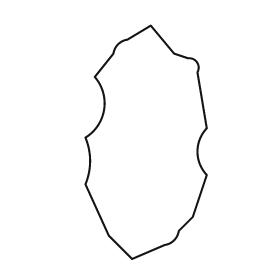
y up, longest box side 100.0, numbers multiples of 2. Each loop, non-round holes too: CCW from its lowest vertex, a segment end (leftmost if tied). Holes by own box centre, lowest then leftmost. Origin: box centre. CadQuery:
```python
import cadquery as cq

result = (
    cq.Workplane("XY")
    .moveTo(-6.0, -50.0)
    .lineTo(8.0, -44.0)
    .threePointArc((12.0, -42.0), (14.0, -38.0))
    .lineTo(20.0, -32.0)
    .lineTo(26.0, -14.0)
    .threePointArc((22.0, -4.0), (26.0, 6.0))
    .lineTo(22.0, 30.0)
    .threePointArc((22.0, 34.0), (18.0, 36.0))
    .lineTo(12.0, 38.0)
    .lineTo(2.0, 50.0)
    .lineTo(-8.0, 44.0)
    .threePointArc((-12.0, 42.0), (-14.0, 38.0))
    .lineTo(-22.0, 28.0)
    .threePointArc((-18.0, 14.0), (-26.0, 2.0))
    .threePointArc((-24.0, -8.0), (-26.0, -18.0))
    .lineTo(-16.0, -40.0)
    .close()
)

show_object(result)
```